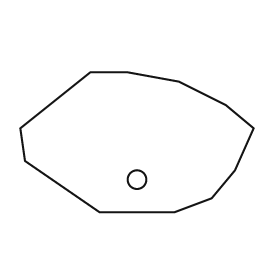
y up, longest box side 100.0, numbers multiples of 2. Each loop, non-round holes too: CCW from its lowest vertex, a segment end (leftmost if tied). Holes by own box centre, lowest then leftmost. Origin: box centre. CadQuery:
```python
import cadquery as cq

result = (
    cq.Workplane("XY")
    .moveTo(-16.0, -30.0)
    .lineTo(16.0, -30.0)
    .lineTo(32.0, -24.0)
    .lineTo(42.0, -12.0)
    .lineTo(50.0, 6.0)
    .lineTo(38.0, 16.0)
    .lineTo(18.0, 26.0)
    .lineTo(-4.0, 30.0)
    .lineTo(-20.0, 30.0)
    .lineTo(-50.0, 6.0)
    .lineTo(-48.0, -8.0)
    .close()
    .moveTo(0.0, -16.0)
    .circle(4.0)
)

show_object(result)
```